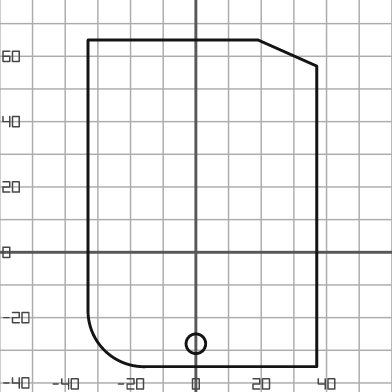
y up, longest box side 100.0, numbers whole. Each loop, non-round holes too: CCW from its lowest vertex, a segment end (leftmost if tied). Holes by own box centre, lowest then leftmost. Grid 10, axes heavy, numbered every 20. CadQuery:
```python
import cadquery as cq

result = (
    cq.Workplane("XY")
    .moveTo(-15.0, -35.0)
    .lineTo(37.0, -35.0)
    .lineTo(37.0, 57.0)
    .lineTo(19.0, 65.0)
    .lineTo(-33.0, 65.0)
    .lineTo(-33.0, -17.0)
    .threePointArc((-28.0, -30.0), (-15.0, -35.0))
    .close()
    .moveTo(0.0, -28.0)
    .circle(3.0)
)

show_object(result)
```